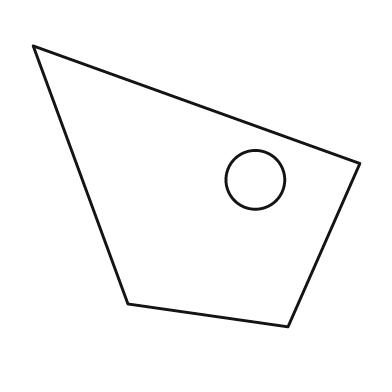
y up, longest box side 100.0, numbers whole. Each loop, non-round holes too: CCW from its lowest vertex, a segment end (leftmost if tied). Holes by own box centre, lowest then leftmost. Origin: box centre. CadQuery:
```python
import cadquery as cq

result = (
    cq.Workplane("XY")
    .moveTo(28.0, -43.0)
    .lineTo(50.0, 7.0)
    .lineTo(-50.0, 43.0)
    .lineTo(-21.0, -36.0)
    .close()
    .moveTo(18.0, 2.0)
    .circle(9.0)
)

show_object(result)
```